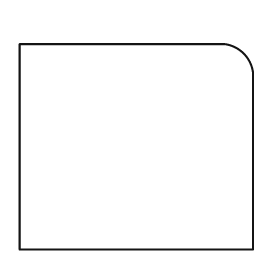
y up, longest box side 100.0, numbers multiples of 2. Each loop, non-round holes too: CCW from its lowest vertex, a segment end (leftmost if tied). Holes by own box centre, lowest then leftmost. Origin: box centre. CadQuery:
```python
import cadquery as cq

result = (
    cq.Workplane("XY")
    .moveTo(-50.0, -44.0)
    .lineTo(50.0, -44.0)
    .lineTo(50.0, 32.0)
    .threePointArc((46.0, 40.0), (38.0, 44.0))
    .lineTo(-50.0, 44.0)
    .close()
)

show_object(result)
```